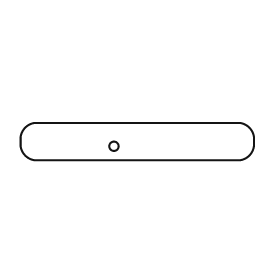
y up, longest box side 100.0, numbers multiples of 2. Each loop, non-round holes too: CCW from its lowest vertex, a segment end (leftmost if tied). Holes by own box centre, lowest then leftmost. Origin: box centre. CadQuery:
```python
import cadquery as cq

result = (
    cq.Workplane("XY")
    .moveTo(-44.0, -8.0)
    .lineTo(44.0, -8.0)
    .threePointArc((48.0, -6.0), (50.0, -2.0))
    .lineTo(50.0, 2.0)
    .threePointArc((48.0, 6.0), (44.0, 8.0))
    .lineTo(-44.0, 8.0)
    .threePointArc((-48.0, 6.0), (-50.0, 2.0))
    .lineTo(-50.0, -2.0)
    .threePointArc((-48.0, -6.0), (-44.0, -8.0))
    .close()
    .moveTo(-10.0, -2.0)
    .circle(2.0)
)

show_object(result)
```